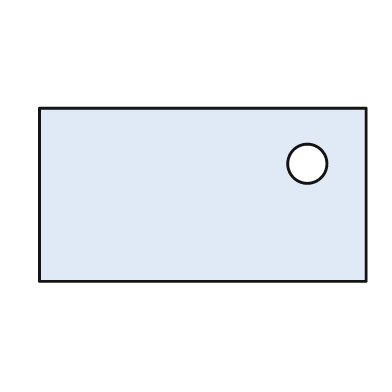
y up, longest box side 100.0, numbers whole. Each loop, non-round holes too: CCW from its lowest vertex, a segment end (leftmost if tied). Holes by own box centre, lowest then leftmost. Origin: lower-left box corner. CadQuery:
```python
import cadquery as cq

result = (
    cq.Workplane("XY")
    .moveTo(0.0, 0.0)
    .lineTo(100.0, 0.0)
    .lineTo(100.0, 53.0)
    .lineTo(0.0, 53.0)
    .close()
    .moveTo(82.0, 36.0)
    .circle(6.0)
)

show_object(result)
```